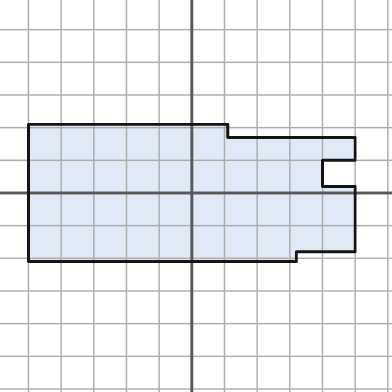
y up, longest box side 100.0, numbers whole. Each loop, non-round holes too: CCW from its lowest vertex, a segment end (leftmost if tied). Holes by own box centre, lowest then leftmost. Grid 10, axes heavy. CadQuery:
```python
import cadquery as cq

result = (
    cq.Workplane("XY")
    .moveTo(-50.0, -21.0)
    .lineTo(32.0, -21.0)
    .lineTo(32.0, -18.0)
    .lineTo(50.0, -18.0)
    .lineTo(50.0, 2.0)
    .lineTo(40.0, 2.0)
    .lineTo(40.0, 10.0)
    .lineTo(50.0, 10.0)
    .lineTo(50.0, 17.0)
    .lineTo(11.0, 17.0)
    .lineTo(11.0, 21.0)
    .lineTo(-50.0, 21.0)
    .close()
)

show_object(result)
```